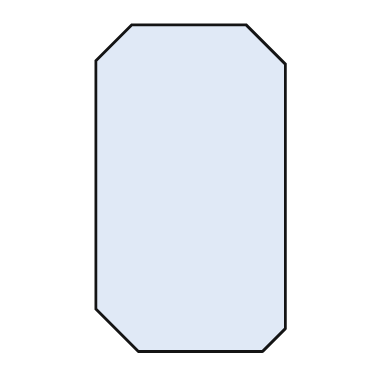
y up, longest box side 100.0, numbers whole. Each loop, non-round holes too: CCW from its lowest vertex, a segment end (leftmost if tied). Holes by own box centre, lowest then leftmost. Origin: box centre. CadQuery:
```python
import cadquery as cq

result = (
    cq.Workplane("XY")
    .moveTo(-16.0, -50.0)
    .lineTo(22.0, -50.0)
    .lineTo(29.0, -43.0)
    .lineTo(29.0, 38.0)
    .lineTo(17.0, 50.0)
    .lineTo(-18.0, 50.0)
    .lineTo(-29.0, 39.0)
    .lineTo(-29.0, -37.0)
    .close()
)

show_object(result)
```